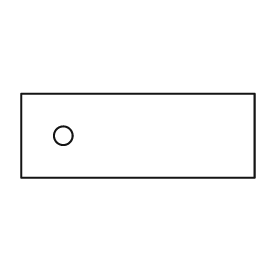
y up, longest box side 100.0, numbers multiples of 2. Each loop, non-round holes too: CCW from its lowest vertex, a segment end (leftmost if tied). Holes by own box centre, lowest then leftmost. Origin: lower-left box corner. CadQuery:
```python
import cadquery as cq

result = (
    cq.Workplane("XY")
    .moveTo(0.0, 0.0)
    .lineTo(100.0, 0.0)
    .lineTo(100.0, 36.0)
    .lineTo(0.0, 36.0)
    .close()
    .moveTo(18.0, 18.0)
    .circle(4.0)
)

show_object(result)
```